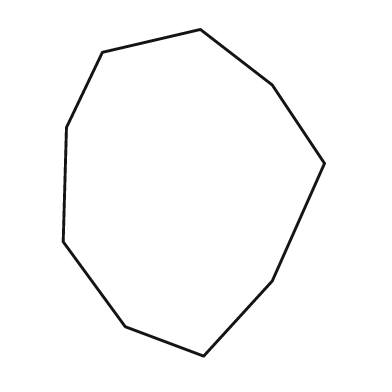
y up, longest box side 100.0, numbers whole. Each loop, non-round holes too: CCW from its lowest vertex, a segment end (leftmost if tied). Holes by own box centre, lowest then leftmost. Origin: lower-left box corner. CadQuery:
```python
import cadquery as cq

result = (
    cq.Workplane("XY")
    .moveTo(43.0, 0.0)
    .lineTo(64.0, 23.0)
    .lineTo(80.0, 59.0)
    .lineTo(64.0, 83.0)
    .lineTo(42.0, 100.0)
    .lineTo(12.0, 93.0)
    .lineTo(1.0, 70.0)
    .lineTo(0.0, 35.0)
    .lineTo(19.0, 9.0)
    .close()
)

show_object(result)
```